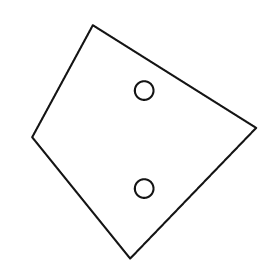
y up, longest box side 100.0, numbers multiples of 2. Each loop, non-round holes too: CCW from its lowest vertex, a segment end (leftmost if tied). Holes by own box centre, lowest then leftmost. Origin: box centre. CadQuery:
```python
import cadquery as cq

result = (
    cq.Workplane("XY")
    .moveTo(-6.0, -50.0)
    .lineTo(48.0, 6.0)
    .lineTo(-22.0, 50.0)
    .lineTo(-48.0, 2.0)
    .close()
    .moveTo(0.0, -20.0)
    .circle(4.0)
    .moveTo(0.0, 22.0)
    .circle(4.0)
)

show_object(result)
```